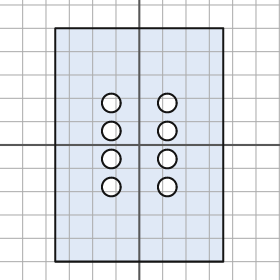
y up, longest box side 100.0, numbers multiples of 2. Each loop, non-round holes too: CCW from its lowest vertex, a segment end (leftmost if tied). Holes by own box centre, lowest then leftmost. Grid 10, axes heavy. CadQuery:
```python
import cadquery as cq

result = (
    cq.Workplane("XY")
    .moveTo(-36.0, -50.0)
    .lineTo(36.0, -50.0)
    .lineTo(36.0, 50.0)
    .lineTo(-36.0, 50.0)
    .close()
    .moveTo(-12.0, -18.0)
    .circle(4.0)
    .moveTo(12.0, -18.0)
    .circle(4.0)
    .moveTo(-12.0, -6.0)
    .circle(4.0)
    .moveTo(12.0, -6.0)
    .circle(4.0)
    .moveTo(-12.0, 6.0)
    .circle(4.0)
    .moveTo(12.0, 6.0)
    .circle(4.0)
    .moveTo(-12.0, 18.0)
    .circle(4.0)
    .moveTo(12.0, 18.0)
    .circle(4.0)
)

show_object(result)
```